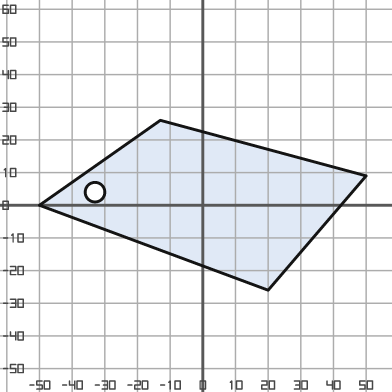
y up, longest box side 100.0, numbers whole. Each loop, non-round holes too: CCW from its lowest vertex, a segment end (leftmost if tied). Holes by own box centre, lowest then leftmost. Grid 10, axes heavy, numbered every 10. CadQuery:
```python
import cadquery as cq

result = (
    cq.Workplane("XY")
    .moveTo(20.0, -26.0)
    .lineTo(50.0, 9.0)
    .lineTo(-13.0, 26.0)
    .lineTo(-50.0, 0.0)
    .close()
    .moveTo(-33.0, 4.0)
    .circle(3.0)
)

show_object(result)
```